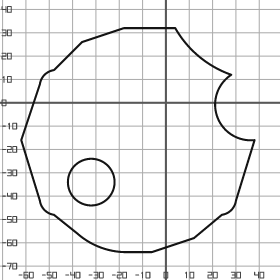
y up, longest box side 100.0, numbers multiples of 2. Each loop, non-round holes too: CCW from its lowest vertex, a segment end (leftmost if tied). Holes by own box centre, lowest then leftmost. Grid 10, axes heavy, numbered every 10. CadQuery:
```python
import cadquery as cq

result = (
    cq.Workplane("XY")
    .moveTo(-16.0, -64.0)
    .lineTo(-6.0, -64.0)
    .lineTo(12.0, -58.0)
    .lineTo(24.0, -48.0)
    .threePointArc((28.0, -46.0), (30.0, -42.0))
    .lineTo(38.0, -16.0)
    .threePointArc((22.0, -6.0), (28.0, 12.0))
    .threePointArc((14.0, 20.0), (4.0, 32.0))
    .lineTo(-18.0, 32.0)
    .lineTo(-36.0, 26.0)
    .lineTo(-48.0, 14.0)
    .threePointArc((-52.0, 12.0), (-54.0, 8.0))
    .lineTo(-62.0, -16.0)
    .lineTo(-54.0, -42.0)
    .threePointArc((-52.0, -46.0), (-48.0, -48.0))
    .lineTo(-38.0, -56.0)
    .threePointArc((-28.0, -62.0), (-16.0, -64.0))
    .close()
    .moveTo(-32.0, -34.0)
    .circle(10.0)
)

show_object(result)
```